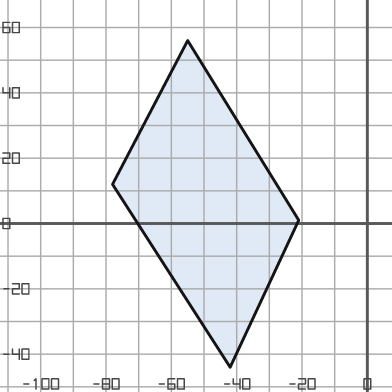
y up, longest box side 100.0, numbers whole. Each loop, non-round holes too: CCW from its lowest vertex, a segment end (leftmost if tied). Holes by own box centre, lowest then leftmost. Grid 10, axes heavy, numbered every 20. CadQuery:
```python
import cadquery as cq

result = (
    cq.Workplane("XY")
    .moveTo(-42.0, -44.0)
    .lineTo(-21.0, 1.0)
    .lineTo(-55.0, 56.0)
    .lineTo(-78.0, 12.0)
    .close()
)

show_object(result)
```